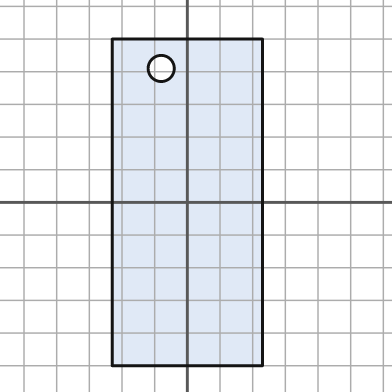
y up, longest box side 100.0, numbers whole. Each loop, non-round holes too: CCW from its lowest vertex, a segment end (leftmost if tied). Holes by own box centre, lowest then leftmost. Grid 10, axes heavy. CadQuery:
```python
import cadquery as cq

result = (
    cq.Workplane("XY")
    .moveTo(-23.0, -50.0)
    .lineTo(23.0, -50.0)
    .lineTo(23.0, 50.0)
    .lineTo(-23.0, 50.0)
    .close()
    .moveTo(-8.0, 41.0)
    .circle(4.0)
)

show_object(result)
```